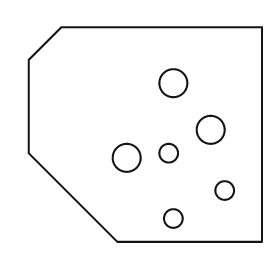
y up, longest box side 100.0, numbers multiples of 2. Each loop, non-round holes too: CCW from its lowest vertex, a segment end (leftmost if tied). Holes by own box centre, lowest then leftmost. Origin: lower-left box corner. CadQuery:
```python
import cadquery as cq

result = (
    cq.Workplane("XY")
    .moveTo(38.0, 0.0)
    .lineTo(100.0, 0.0)
    .lineTo(100.0, 92.0)
    .lineTo(14.0, 92.0)
    .lineTo(0.0, 78.0)
    .lineTo(0.0, 38.0)
    .close()
    .moveTo(62.0, 10.0)
    .circle(4.0)
    .moveTo(84.0, 22.0)
    .circle(4.0)
    .moveTo(42.0, 36.0)
    .circle(6.0)
    .moveTo(60.0, 38.0)
    .circle(4.0)
    .moveTo(78.0, 48.0)
    .circle(6.0)
    .moveTo(62.0, 68.0)
    .circle(6.0)
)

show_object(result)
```